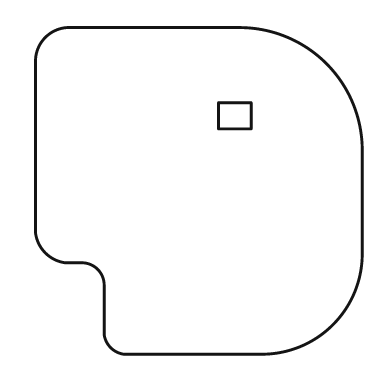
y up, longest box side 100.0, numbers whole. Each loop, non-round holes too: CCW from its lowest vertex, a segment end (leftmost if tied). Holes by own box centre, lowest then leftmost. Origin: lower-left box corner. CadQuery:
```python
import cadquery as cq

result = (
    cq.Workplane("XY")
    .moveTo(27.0, 0.0)
    .lineTo(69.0, 0.0)
    .threePointArc((91.0, 9.0), (100.0, 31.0))
    .lineTo(100.0, 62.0)
    .threePointArc((89.0, 89.0), (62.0, 100.0))
    .lineTo(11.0, 100.0)
    .threePointArc((3.0, 97.0), (0.0, 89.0))
    .lineTo(0.0, 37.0)
    .threePointArc((3.0, 31.0), (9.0, 28.0))
    .lineTo(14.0, 28.0)
    .threePointArc((19.0, 26.0), (21.0, 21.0))
    .lineTo(21.0, 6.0)
    .threePointArc((23.0, 2.0), (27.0, 0.0))
    .close()
    .moveTo(56.0, 69.0)
    .lineTo(66.0, 69.0)
    .lineTo(66.0, 77.0)
    .lineTo(56.0, 77.0)
    .close()
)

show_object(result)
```